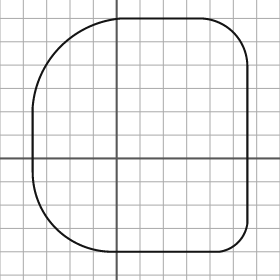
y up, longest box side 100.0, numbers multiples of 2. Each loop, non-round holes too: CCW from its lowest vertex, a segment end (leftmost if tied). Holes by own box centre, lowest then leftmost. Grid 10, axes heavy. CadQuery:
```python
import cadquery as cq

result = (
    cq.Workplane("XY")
    .moveTo(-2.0, -40.0)
    .lineTo(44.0, -40.0)
    .threePointArc((52.0, -36.0), (56.0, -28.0))
    .lineTo(56.0, 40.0)
    .threePointArc((50.0, 54.0), (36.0, 60.0))
    .lineTo(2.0, 60.0)
    .threePointArc((-24.0, 48.0), (-36.0, 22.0))
    .lineTo(-36.0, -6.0)
    .threePointArc((-26.0, -30.0), (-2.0, -40.0))
    .close()
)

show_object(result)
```